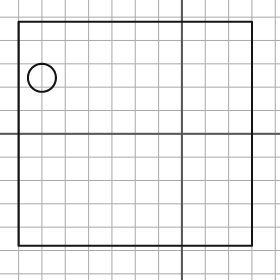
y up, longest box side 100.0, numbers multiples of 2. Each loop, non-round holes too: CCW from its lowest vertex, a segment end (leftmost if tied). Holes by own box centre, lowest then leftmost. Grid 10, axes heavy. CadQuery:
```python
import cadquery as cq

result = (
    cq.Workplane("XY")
    .moveTo(-70.0, -48.0)
    .lineTo(30.0, -48.0)
    .lineTo(30.0, 48.0)
    .lineTo(-70.0, 48.0)
    .close()
    .moveTo(-60.0, 24.0)
    .circle(6.0)
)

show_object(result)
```